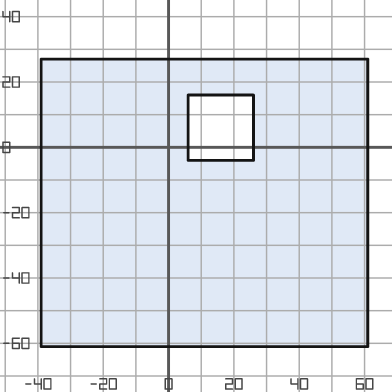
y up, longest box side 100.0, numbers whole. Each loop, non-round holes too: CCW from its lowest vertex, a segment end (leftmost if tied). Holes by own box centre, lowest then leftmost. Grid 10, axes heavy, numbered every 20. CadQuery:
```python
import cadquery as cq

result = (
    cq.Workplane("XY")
    .moveTo(-39.0, -61.0)
    .lineTo(61.0, -61.0)
    .lineTo(61.0, 27.0)
    .lineTo(-39.0, 27.0)
    .close()
    .moveTo(6.0, -4.0)
    .lineTo(26.0, -4.0)
    .lineTo(26.0, 16.0)
    .lineTo(6.0, 16.0)
    .close()
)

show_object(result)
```